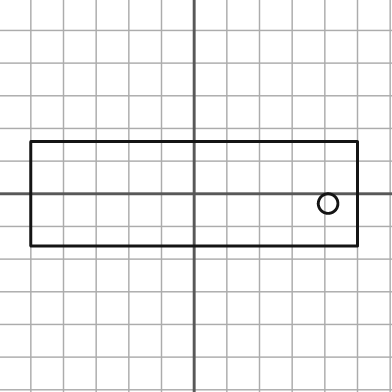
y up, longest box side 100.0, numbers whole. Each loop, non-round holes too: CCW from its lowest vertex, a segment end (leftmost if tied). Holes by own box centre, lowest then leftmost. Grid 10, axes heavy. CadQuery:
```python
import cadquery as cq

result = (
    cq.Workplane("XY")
    .moveTo(-50.0, -16.0)
    .lineTo(50.0, -16.0)
    .lineTo(50.0, 16.0)
    .lineTo(-50.0, 16.0)
    .close()
    .moveTo(41.0, -3.0)
    .circle(3.0)
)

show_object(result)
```